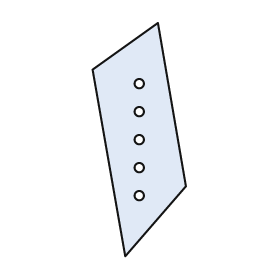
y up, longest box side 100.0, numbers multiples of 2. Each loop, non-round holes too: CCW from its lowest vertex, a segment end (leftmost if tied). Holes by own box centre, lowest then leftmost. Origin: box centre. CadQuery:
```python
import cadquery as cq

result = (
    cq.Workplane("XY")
    .moveTo(-6.0, -50.0)
    .lineTo(20.0, -20.0)
    .lineTo(8.0, 50.0)
    .lineTo(-20.0, 30.0)
    .close()
    .moveTo(0.0, -24.0)
    .circle(2.0)
    .moveTo(0.0, -12.0)
    .circle(2.0)
    .moveTo(0.0, 0.0)
    .circle(2.0)
    .moveTo(0.0, 12.0)
    .circle(2.0)
    .moveTo(0.0, 24.0)
    .circle(2.0)
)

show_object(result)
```